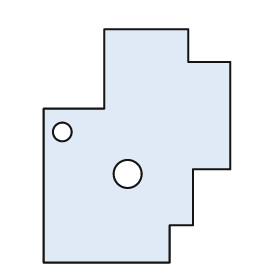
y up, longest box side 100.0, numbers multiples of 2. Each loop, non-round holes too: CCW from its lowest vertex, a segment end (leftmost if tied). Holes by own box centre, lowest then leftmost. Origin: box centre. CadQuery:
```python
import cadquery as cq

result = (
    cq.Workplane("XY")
    .moveTo(-40.0, -50.0)
    .lineTo(14.0, -50.0)
    .lineTo(14.0, -34.0)
    .lineTo(24.0, -34.0)
    .lineTo(24.0, -10.0)
    .lineTo(40.0, -10.0)
    .lineTo(40.0, 36.0)
    .lineTo(22.0, 36.0)
    .lineTo(22.0, 50.0)
    .lineTo(-14.0, 50.0)
    .lineTo(-14.0, 16.0)
    .lineTo(-40.0, 16.0)
    .close()
    .moveTo(-4.0, -12.0)
    .circle(6.0)
    .moveTo(-32.0, 6.0)
    .circle(4.0)
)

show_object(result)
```